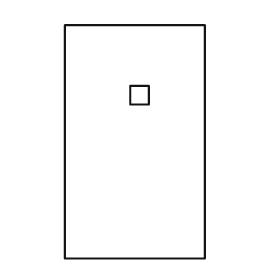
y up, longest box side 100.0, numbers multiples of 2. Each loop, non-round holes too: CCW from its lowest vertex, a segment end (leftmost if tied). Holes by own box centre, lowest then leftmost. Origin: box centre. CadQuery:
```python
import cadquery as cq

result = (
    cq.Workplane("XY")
    .moveTo(-30.0, -50.0)
    .lineTo(30.0, -50.0)
    .lineTo(30.0, 50.0)
    .lineTo(-30.0, 50.0)
    .close()
    .moveTo(-2.0, 16.0)
    .lineTo(6.0, 16.0)
    .lineTo(6.0, 24.0)
    .lineTo(-2.0, 24.0)
    .close()
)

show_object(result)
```